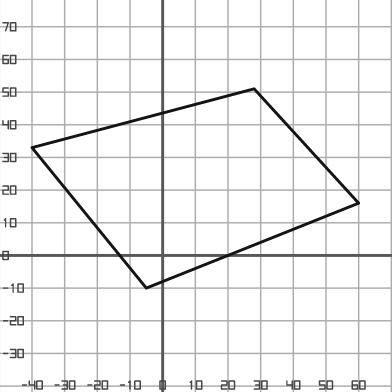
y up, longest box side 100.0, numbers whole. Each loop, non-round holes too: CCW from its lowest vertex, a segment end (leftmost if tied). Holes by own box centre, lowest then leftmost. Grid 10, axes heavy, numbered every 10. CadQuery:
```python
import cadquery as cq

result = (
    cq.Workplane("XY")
    .moveTo(-5.0, -10.0)
    .lineTo(60.0, 16.0)
    .lineTo(28.0, 51.0)
    .lineTo(-40.0, 33.0)
    .close()
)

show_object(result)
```